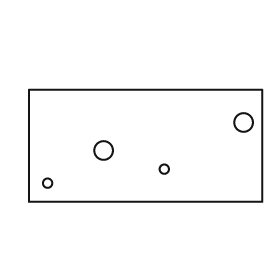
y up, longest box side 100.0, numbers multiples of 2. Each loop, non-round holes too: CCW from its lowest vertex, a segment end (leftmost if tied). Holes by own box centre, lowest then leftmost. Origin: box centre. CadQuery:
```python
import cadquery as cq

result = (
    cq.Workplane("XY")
    .moveTo(-50.0, -24.0)
    .lineTo(50.0, -24.0)
    .lineTo(50.0, 24.0)
    .lineTo(-50.0, 24.0)
    .close()
    .moveTo(-42.0, -16.0)
    .circle(2.0)
    .moveTo(8.0, -10.0)
    .circle(2.0)
    .moveTo(-18.0, -2.0)
    .circle(4.0)
    .moveTo(42.0, 10.0)
    .circle(4.0)
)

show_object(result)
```